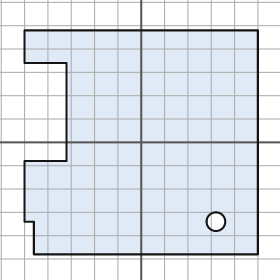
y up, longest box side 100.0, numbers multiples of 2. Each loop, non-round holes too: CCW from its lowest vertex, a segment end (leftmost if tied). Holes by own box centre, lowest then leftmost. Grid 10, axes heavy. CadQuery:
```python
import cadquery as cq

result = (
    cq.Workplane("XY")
    .moveTo(-46.0, -48.0)
    .lineTo(50.0, -48.0)
    .lineTo(50.0, 48.0)
    .lineTo(-50.0, 48.0)
    .lineTo(-50.0, 34.0)
    .lineTo(-32.0, 34.0)
    .lineTo(-32.0, -8.0)
    .lineTo(-50.0, -8.0)
    .lineTo(-50.0, -34.0)
    .lineTo(-46.0, -34.0)
    .close()
    .moveTo(32.0, -34.0)
    .circle(4.0)
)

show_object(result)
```